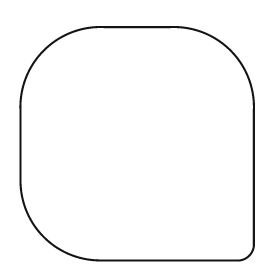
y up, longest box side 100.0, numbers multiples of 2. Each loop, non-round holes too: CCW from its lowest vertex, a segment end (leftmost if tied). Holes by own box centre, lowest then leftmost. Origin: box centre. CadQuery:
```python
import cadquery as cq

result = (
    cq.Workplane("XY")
    .moveTo(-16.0, -50.0)
    .lineTo(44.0, -50.0)
    .threePointArc((48.0, -48.0), (50.0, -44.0))
    .lineTo(50.0, 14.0)
    .threePointArc((40.0, 40.0), (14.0, 50.0))
    .lineTo(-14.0, 50.0)
    .threePointArc((-40.0, 40.0), (-50.0, 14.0))
    .lineTo(-50.0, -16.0)
    .threePointArc((-40.0, -40.0), (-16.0, -50.0))
    .close()
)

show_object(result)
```